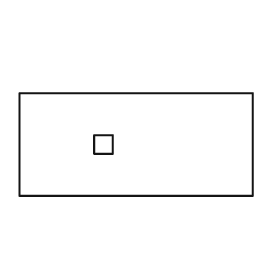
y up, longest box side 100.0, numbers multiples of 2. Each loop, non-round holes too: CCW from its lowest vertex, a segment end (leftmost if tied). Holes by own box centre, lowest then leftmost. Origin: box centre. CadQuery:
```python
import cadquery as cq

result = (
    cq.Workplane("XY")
    .moveTo(-50.0, -22.0)
    .lineTo(50.0, -22.0)
    .lineTo(50.0, 22.0)
    .lineTo(-50.0, 22.0)
    .close()
    .moveTo(-18.0, -4.0)
    .lineTo(-10.0, -4.0)
    .lineTo(-10.0, 4.0)
    .lineTo(-18.0, 4.0)
    .close()
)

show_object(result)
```